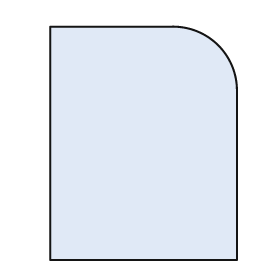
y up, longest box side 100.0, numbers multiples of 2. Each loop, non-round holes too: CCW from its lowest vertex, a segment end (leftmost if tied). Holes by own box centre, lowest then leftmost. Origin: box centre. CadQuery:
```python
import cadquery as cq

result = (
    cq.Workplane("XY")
    .moveTo(-40.0, -50.0)
    .lineTo(40.0, -50.0)
    .lineTo(40.0, 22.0)
    .threePointArc((32.0, 42.0), (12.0, 50.0))
    .lineTo(-40.0, 50.0)
    .close()
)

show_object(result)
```